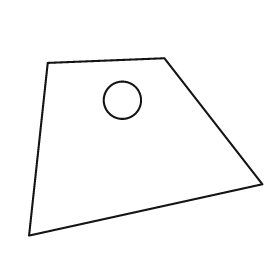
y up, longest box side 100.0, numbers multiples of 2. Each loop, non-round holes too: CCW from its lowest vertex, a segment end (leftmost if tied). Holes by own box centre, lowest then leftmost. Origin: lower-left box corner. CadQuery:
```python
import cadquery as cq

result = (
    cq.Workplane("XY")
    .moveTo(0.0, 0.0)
    .lineTo(100.0, 22.0)
    .lineTo(58.0, 76.0)
    .lineTo(8.0, 74.0)
    .close()
    .moveTo(40.0, 58.0)
    .circle(8.0)
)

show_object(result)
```